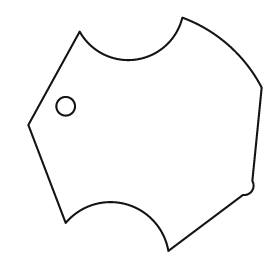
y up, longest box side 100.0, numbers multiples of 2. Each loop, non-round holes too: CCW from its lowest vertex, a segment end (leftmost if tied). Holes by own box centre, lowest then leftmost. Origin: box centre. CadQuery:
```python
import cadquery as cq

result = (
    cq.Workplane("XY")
    .moveTo(10.0, -50.0)
    .lineTo(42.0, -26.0)
    .threePointArc((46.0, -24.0), (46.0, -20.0))
    .lineTo(50.0, 20.0)
    .threePointArc((36.0, 38.0), (16.0, 50.0))
    .threePointArc((-4.0, 32.0), (-28.0, 44.0))
    .lineTo(-50.0, 4.0)
    .lineTo(-34.0, -38.0)
    .threePointArc((-8.0, -30.0), (10.0, -50.0))
    .close()
    .moveTo(-34.0, 12.0)
    .circle(4.0)
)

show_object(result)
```